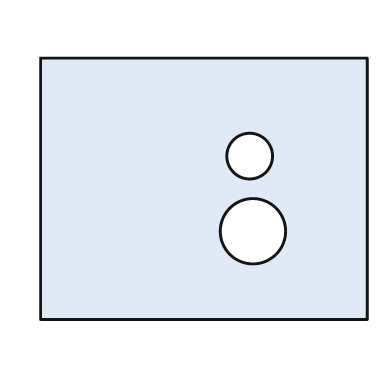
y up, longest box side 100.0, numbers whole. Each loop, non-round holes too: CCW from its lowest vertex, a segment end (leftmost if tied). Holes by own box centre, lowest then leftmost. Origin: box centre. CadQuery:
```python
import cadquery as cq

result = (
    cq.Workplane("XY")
    .moveTo(-50.0, -40.0)
    .lineTo(50.0, -40.0)
    .lineTo(50.0, 40.0)
    .lineTo(-50.0, 40.0)
    .close()
    .moveTo(15.0, -13.0)
    .circle(10.0)
    .moveTo(14.0, 10.0)
    .circle(7.0)
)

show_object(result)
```